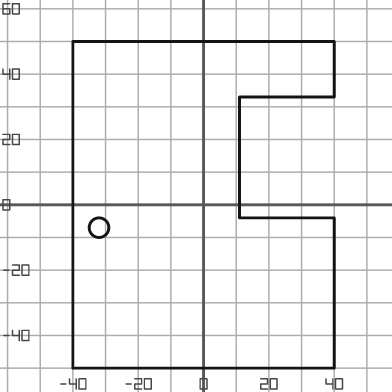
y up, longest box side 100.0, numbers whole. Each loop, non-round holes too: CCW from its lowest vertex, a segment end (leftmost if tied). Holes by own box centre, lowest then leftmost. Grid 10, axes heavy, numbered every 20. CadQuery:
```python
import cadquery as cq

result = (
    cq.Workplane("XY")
    .moveTo(-40.0, -50.0)
    .lineTo(40.0, -50.0)
    .lineTo(40.0, -4.0)
    .lineTo(11.0, -4.0)
    .lineTo(11.0, 33.0)
    .lineTo(40.0, 33.0)
    .lineTo(40.0, 50.0)
    .lineTo(-40.0, 50.0)
    .close()
    .moveTo(-32.0, -7.0)
    .circle(3.0)
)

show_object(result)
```